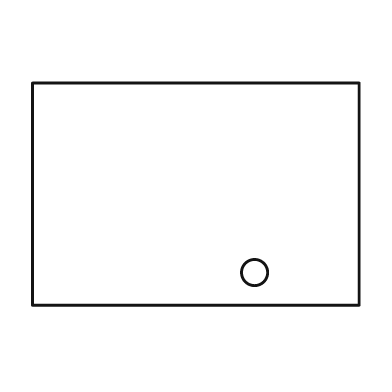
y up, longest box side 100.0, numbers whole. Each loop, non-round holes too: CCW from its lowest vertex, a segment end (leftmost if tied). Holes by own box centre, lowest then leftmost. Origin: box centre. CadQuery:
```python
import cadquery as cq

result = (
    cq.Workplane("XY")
    .moveTo(-50.0, -34.0)
    .lineTo(50.0, -34.0)
    .lineTo(50.0, 34.0)
    .lineTo(-50.0, 34.0)
    .close()
    .moveTo(18.0, -24.0)
    .circle(4.0)
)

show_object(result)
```